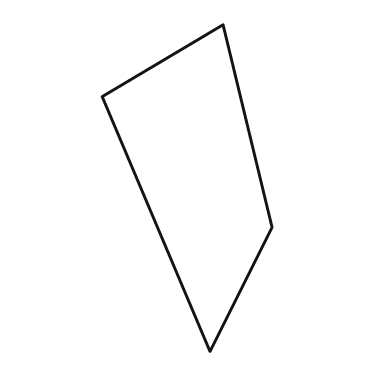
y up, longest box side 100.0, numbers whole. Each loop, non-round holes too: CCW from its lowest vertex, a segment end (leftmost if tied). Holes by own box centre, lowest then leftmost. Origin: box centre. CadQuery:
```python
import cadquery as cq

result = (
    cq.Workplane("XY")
    .moveTo(7.0, -50.0)
    .lineTo(26.0, -12.0)
    .lineTo(11.0, 50.0)
    .lineTo(-26.0, 28.0)
    .close()
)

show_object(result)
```